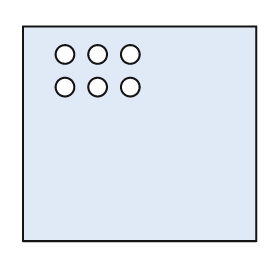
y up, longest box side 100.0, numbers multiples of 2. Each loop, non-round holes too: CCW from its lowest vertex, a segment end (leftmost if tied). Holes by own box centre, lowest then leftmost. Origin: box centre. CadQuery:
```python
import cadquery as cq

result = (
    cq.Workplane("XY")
    .moveTo(-50.0, -46.0)
    .lineTo(50.0, -46.0)
    .lineTo(50.0, 46.0)
    .lineTo(-50.0, 46.0)
    .close()
    .moveTo(-32.0, 20.0)
    .circle(4.0)
    .moveTo(-18.0, 20.0)
    .circle(4.0)
    .moveTo(-4.0, 20.0)
    .circle(4.0)
    .moveTo(-32.0, 34.0)
    .circle(4.0)
    .moveTo(-18.0, 34.0)
    .circle(4.0)
    .moveTo(-4.0, 34.0)
    .circle(4.0)
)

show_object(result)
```